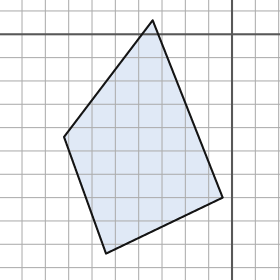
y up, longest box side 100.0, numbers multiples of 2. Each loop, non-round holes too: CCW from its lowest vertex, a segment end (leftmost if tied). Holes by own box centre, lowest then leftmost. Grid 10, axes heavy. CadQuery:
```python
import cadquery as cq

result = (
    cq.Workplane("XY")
    .moveTo(-54.0, -94.0)
    .lineTo(-4.0, -70.0)
    .lineTo(-34.0, 6.0)
    .lineTo(-72.0, -44.0)
    .close()
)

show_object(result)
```